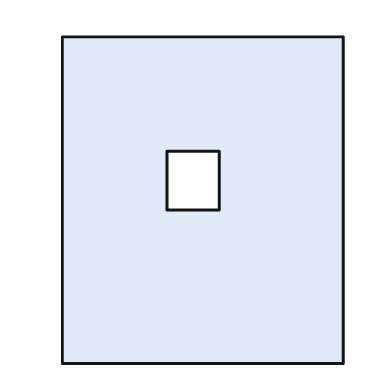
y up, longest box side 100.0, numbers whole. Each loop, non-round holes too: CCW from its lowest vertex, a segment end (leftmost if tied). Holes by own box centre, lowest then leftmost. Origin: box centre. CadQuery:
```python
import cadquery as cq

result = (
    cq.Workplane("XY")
    .moveTo(-43.0, -50.0)
    .lineTo(43.0, -50.0)
    .lineTo(43.0, 50.0)
    .lineTo(-43.0, 50.0)
    .close()
    .moveTo(-11.0, -3.0)
    .lineTo(5.0, -3.0)
    .lineTo(5.0, 15.0)
    .lineTo(-11.0, 15.0)
    .close()
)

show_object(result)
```